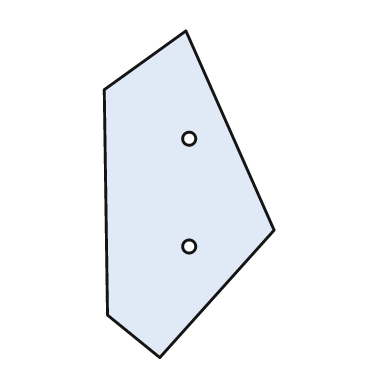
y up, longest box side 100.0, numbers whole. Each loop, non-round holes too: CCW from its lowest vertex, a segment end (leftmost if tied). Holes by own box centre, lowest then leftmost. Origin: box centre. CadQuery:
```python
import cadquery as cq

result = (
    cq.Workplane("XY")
    .moveTo(-9.0, -50.0)
    .lineTo(26.0, -11.0)
    .lineTo(-1.0, 50.0)
    .lineTo(-26.0, 32.0)
    .lineTo(-25.0, -37.0)
    .close()
    .moveTo(0.0, -16.0)
    .circle(2.0)
    .moveTo(0.0, 17.0)
    .circle(2.0)
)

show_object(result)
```